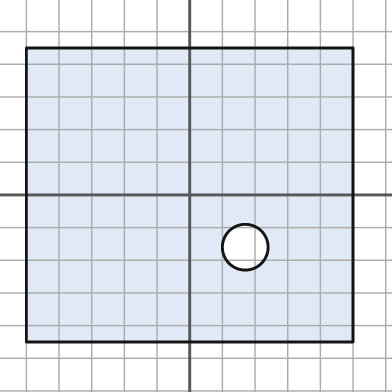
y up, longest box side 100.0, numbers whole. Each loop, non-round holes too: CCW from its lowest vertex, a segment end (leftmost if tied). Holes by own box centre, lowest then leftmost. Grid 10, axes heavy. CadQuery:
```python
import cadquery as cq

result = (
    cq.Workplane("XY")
    .moveTo(-50.0, -45.0)
    .lineTo(50.0, -45.0)
    .lineTo(50.0, 45.0)
    .lineTo(-50.0, 45.0)
    .close()
    .moveTo(17.0, -16.0)
    .circle(7.0)
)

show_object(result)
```